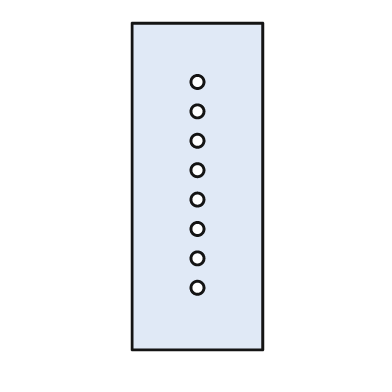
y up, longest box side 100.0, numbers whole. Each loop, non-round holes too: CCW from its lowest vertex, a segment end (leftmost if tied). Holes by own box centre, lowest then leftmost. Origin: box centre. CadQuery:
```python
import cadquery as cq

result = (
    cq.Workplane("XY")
    .moveTo(-20.0, -50.0)
    .lineTo(20.0, -50.0)
    .lineTo(20.0, 50.0)
    .lineTo(-20.0, 50.0)
    .close()
    .moveTo(0.0, -31.0)
    .circle(2.0)
    .moveTo(0.0, -22.0)
    .circle(2.0)
    .moveTo(0.0, -13.0)
    .circle(2.0)
    .moveTo(0.0, -4.0)
    .circle(2.0)
    .moveTo(0.0, 5.0)
    .circle(2.0)
    .moveTo(0.0, 14.0)
    .circle(2.0)
    .moveTo(0.0, 23.0)
    .circle(2.0)
    .moveTo(0.0, 32.0)
    .circle(2.0)
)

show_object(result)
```